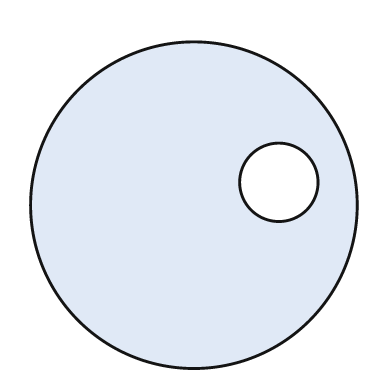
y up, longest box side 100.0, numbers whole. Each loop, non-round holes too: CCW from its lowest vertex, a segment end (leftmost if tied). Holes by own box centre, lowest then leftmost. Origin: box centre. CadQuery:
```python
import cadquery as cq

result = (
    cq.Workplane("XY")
    .moveTo(0.0, 0.0)
    .circle(50.0)
    .moveTo(26.0, 7.0)
    .circle(12.0)
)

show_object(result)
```